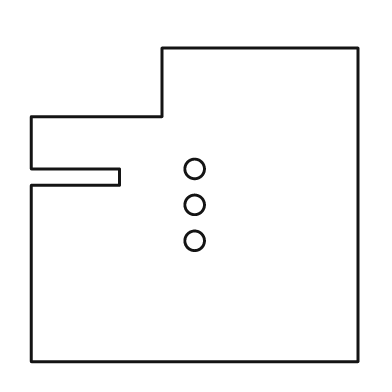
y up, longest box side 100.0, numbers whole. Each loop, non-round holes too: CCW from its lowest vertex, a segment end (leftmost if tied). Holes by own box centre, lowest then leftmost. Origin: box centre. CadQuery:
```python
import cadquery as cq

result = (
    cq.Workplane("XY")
    .moveTo(-50.0, -48.0)
    .lineTo(50.0, -48.0)
    .lineTo(50.0, 48.0)
    .lineTo(-10.0, 48.0)
    .lineTo(-10.0, 27.0)
    .lineTo(-50.0, 27.0)
    .lineTo(-50.0, 11.0)
    .lineTo(-23.0, 11.0)
    .lineTo(-23.0, 6.0)
    .lineTo(-50.0, 6.0)
    .close()
    .moveTo(0.0, -11.0)
    .circle(3.0)
    .moveTo(0.0, 0.0)
    .circle(3.0)
    .moveTo(0.0, 11.0)
    .circle(3.0)
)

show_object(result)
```